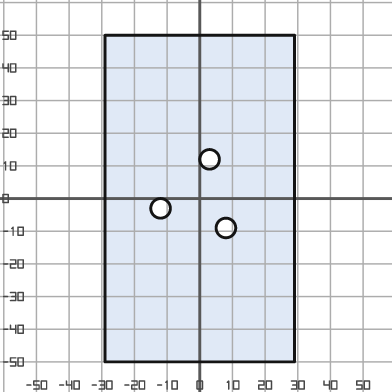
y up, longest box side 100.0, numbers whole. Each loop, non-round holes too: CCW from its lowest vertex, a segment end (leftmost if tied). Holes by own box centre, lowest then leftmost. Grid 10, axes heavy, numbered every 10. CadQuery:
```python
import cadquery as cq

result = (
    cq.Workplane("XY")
    .moveTo(-29.0, -50.0)
    .lineTo(29.0, -50.0)
    .lineTo(29.0, 50.0)
    .lineTo(-29.0, 50.0)
    .close()
    .moveTo(8.0, -9.0)
    .circle(3.0)
    .moveTo(-12.0, -3.0)
    .circle(3.0)
    .moveTo(3.0, 12.0)
    .circle(3.0)
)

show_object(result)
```